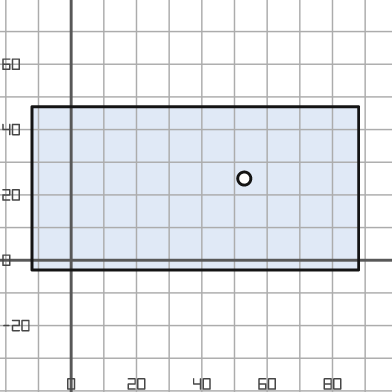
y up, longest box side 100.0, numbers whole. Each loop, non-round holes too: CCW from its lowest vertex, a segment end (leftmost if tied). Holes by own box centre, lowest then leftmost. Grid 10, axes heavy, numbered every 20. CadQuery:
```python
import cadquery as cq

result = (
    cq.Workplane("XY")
    .moveTo(-12.0, -3.0)
    .lineTo(88.0, -3.0)
    .lineTo(88.0, 47.0)
    .lineTo(-12.0, 47.0)
    .close()
    .moveTo(53.0, 25.0)
    .circle(2.0)
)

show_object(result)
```